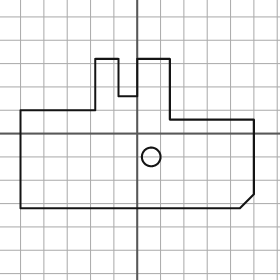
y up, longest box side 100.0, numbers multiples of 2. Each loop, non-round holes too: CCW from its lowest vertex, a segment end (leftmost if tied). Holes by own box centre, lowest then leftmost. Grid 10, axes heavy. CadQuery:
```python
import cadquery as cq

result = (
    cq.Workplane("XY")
    .moveTo(-50.0, -32.0)
    .lineTo(44.0, -32.0)
    .lineTo(50.0, -26.0)
    .lineTo(50.0, 6.0)
    .lineTo(14.0, 6.0)
    .lineTo(14.0, 32.0)
    .lineTo(0.0, 32.0)
    .lineTo(0.0, 16.0)
    .lineTo(-8.0, 16.0)
    .lineTo(-8.0, 32.0)
    .lineTo(-18.0, 32.0)
    .lineTo(-18.0, 10.0)
    .lineTo(-50.0, 10.0)
    .close()
    .moveTo(6.0, -10.0)
    .circle(4.0)
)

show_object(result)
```